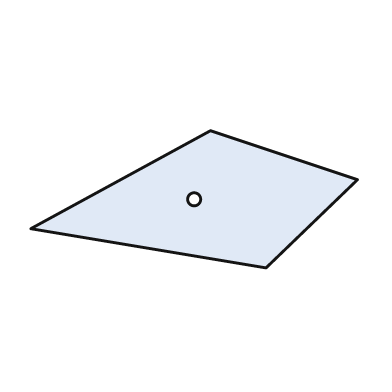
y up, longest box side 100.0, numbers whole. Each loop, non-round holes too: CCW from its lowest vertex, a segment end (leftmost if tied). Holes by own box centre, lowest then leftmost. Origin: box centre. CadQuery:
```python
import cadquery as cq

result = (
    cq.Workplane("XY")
    .moveTo(22.0, -21.0)
    .lineTo(50.0, 6.0)
    .lineTo(5.0, 21.0)
    .lineTo(-50.0, -9.0)
    .close()
    .moveTo(0.0, 0.0)
    .circle(2.0)
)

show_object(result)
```